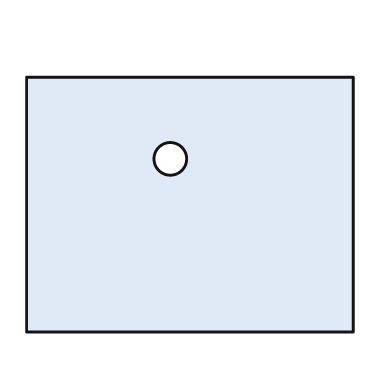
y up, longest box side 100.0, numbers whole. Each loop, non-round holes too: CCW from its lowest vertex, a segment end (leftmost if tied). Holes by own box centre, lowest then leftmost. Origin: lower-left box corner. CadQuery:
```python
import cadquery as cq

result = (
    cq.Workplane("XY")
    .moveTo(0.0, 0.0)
    .lineTo(100.0, 0.0)
    .lineTo(100.0, 78.0)
    .lineTo(0.0, 78.0)
    .close()
    .moveTo(44.0, 53.0)
    .circle(5.0)
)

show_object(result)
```